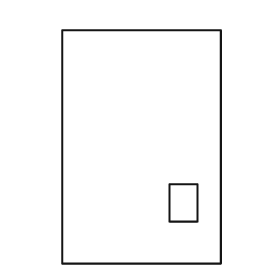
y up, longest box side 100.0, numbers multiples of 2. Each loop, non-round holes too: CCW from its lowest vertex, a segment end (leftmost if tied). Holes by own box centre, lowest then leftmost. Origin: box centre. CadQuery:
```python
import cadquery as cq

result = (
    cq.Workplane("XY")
    .moveTo(-34.0, -50.0)
    .lineTo(34.0, -50.0)
    .lineTo(34.0, 50.0)
    .lineTo(-34.0, 50.0)
    .close()
    .moveTo(12.0, -32.0)
    .lineTo(24.0, -32.0)
    .lineTo(24.0, -16.0)
    .lineTo(12.0, -16.0)
    .close()
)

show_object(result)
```